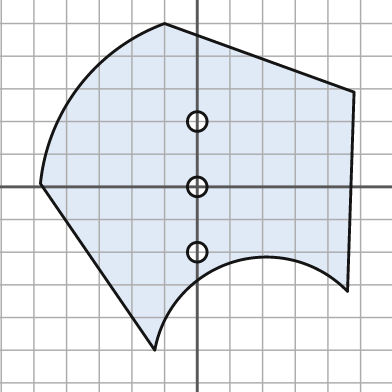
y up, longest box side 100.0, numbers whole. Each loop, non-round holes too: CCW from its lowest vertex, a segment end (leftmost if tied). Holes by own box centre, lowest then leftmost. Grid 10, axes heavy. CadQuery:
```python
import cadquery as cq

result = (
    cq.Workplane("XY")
    .moveTo(-13.0, -50.0)
    .threePointArc((11.0, -23.0), (46.0, -32.0))
    .lineTo(48.0, 29.0)
    .lineTo(-10.0, 50.0)
    .threePointArc((-36.0, 31.0), (-48.0, 1.0))
    .close()
    .moveTo(0.0, -20.0)
    .circle(3.0)
    .moveTo(0.0, 0.0)
    .circle(3.0)
    .moveTo(0.0, 20.0)
    .circle(3.0)
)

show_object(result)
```